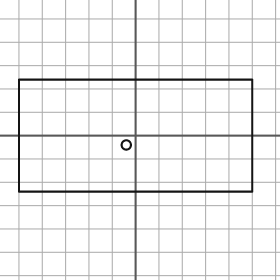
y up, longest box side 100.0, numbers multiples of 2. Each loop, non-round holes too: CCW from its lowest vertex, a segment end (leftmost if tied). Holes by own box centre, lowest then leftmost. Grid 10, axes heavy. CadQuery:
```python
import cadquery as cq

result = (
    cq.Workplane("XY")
    .moveTo(-50.0, -24.0)
    .lineTo(50.0, -24.0)
    .lineTo(50.0, 24.0)
    .lineTo(-50.0, 24.0)
    .close()
    .moveTo(-4.0, -4.0)
    .circle(2.0)
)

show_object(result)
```